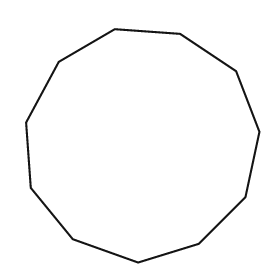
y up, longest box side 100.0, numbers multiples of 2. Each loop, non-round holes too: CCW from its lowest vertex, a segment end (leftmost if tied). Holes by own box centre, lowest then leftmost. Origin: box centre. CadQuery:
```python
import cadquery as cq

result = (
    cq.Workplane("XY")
    .moveTo(-2.0, -50.0)
    .lineTo(24.0, -42.0)
    .lineTo(44.0, -22.0)
    .lineTo(50.0, 6.0)
    .lineTo(40.0, 32.0)
    .lineTo(16.0, 48.0)
    .lineTo(-12.0, 50.0)
    .lineTo(-36.0, 36.0)
    .lineTo(-50.0, 10.0)
    .lineTo(-48.0, -18.0)
    .lineTo(-30.0, -40.0)
    .close()
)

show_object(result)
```